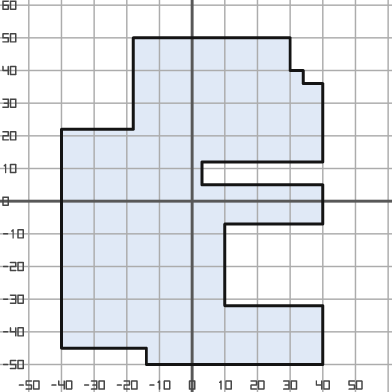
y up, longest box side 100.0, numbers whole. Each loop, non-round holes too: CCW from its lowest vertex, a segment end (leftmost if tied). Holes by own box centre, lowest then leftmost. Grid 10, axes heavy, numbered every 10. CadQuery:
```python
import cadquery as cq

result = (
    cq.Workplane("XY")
    .moveTo(-14.0, -50.0)
    .lineTo(40.0, -50.0)
    .lineTo(40.0, -32.0)
    .lineTo(10.0, -32.0)
    .lineTo(10.0, -7.0)
    .lineTo(40.0, -7.0)
    .lineTo(40.0, 5.0)
    .lineTo(3.0, 5.0)
    .lineTo(3.0, 12.0)
    .lineTo(40.0, 12.0)
    .lineTo(40.0, 36.0)
    .lineTo(34.0, 36.0)
    .lineTo(34.0, 40.0)
    .lineTo(30.0, 40.0)
    .lineTo(30.0, 50.0)
    .lineTo(-18.0, 50.0)
    .lineTo(-18.0, 22.0)
    .lineTo(-40.0, 22.0)
    .lineTo(-40.0, -45.0)
    .lineTo(-14.0, -45.0)
    .close()
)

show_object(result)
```